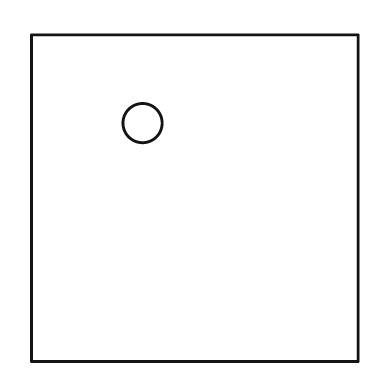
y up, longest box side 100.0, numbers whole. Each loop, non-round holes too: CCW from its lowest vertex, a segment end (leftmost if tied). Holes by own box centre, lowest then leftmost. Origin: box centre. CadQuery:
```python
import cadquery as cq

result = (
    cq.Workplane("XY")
    .moveTo(-50.0, -50.0)
    .lineTo(50.0, -50.0)
    .lineTo(50.0, 50.0)
    .lineTo(-50.0, 50.0)
    .close()
    .moveTo(-16.0, 23.0)
    .circle(6.0)
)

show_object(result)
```